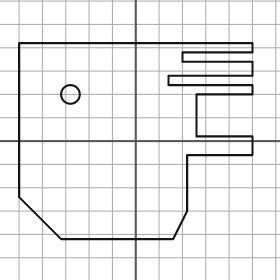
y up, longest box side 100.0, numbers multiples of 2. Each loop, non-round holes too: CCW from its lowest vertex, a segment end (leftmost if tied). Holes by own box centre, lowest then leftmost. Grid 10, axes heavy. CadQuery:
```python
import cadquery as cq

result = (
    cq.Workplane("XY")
    .moveTo(-32.0, -42.0)
    .lineTo(16.0, -42.0)
    .lineTo(22.0, -30.0)
    .lineTo(22.0, -6.0)
    .lineTo(50.0, -6.0)
    .lineTo(50.0, 2.0)
    .lineTo(26.0, 2.0)
    .lineTo(26.0, 20.0)
    .lineTo(50.0, 20.0)
    .lineTo(50.0, 24.0)
    .lineTo(14.0, 24.0)
    .lineTo(14.0, 28.0)
    .lineTo(50.0, 28.0)
    .lineTo(50.0, 34.0)
    .lineTo(20.0, 34.0)
    .lineTo(20.0, 38.0)
    .lineTo(50.0, 38.0)
    .lineTo(50.0, 42.0)
    .lineTo(-50.0, 42.0)
    .lineTo(-50.0, -24.0)
    .close()
    .moveTo(-28.0, 20.0)
    .circle(4.0)
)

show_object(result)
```